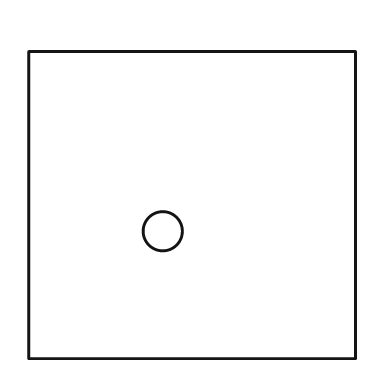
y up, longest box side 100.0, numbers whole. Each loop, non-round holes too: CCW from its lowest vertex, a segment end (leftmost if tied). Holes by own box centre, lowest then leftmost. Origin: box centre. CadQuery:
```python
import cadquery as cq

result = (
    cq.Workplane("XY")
    .moveTo(-50.0, -47.0)
    .lineTo(50.0, -47.0)
    .lineTo(50.0, 47.0)
    .lineTo(-50.0, 47.0)
    .close()
    .moveTo(-9.0, -8.0)
    .circle(6.0)
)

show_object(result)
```